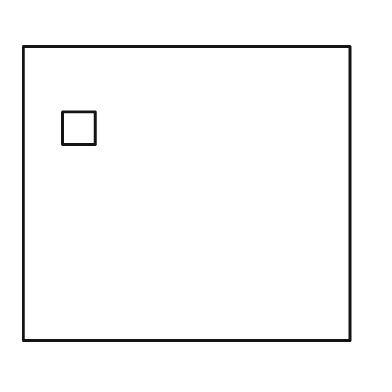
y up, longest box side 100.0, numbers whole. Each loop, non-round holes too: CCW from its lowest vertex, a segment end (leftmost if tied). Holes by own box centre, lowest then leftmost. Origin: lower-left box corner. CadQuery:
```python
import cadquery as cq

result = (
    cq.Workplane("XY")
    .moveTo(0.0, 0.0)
    .lineTo(100.0, 0.0)
    .lineTo(100.0, 90.0)
    .lineTo(0.0, 90.0)
    .close()
    .moveTo(12.0, 60.0)
    .lineTo(22.0, 60.0)
    .lineTo(22.0, 70.0)
    .lineTo(12.0, 70.0)
    .close()
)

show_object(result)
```